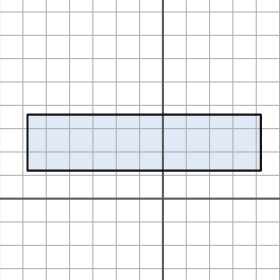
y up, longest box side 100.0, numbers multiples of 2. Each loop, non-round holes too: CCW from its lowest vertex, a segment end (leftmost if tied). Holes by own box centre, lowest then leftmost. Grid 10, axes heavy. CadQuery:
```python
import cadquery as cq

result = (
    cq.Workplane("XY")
    .moveTo(-58.0, 12.0)
    .lineTo(42.0, 12.0)
    .lineTo(42.0, 36.0)
    .lineTo(-58.0, 36.0)
    .close()
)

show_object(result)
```